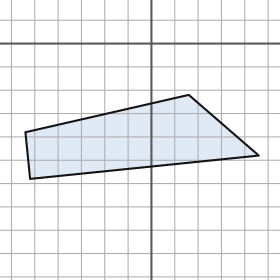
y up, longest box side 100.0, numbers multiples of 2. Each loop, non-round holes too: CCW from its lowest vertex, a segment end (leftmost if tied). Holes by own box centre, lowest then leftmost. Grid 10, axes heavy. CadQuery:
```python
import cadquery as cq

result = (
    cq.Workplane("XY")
    .moveTo(-52.0, -58.0)
    .lineTo(46.0, -48.0)
    .lineTo(16.0, -22.0)
    .lineTo(-54.0, -38.0)
    .close()
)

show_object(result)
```